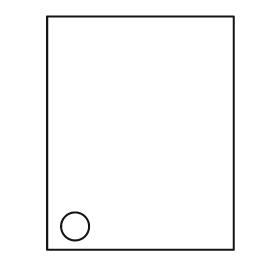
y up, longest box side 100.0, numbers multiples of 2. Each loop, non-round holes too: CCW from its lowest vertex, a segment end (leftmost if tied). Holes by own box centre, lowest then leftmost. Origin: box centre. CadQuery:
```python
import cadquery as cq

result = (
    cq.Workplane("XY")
    .moveTo(-40.0, -50.0)
    .lineTo(40.0, -50.0)
    .lineTo(40.0, 50.0)
    .lineTo(-40.0, 50.0)
    .close()
    .moveTo(-28.0, -40.0)
    .circle(6.0)
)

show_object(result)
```